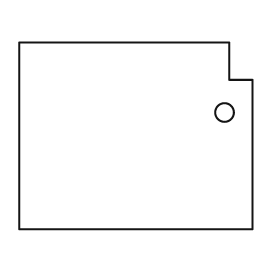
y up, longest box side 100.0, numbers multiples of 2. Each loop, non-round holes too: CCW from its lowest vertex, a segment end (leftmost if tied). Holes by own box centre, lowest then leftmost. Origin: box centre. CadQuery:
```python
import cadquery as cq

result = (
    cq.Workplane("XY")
    .moveTo(-50.0, -40.0)
    .lineTo(50.0, -40.0)
    .lineTo(50.0, 24.0)
    .lineTo(40.0, 24.0)
    .lineTo(40.0, 40.0)
    .lineTo(-50.0, 40.0)
    .close()
    .moveTo(38.0, 10.0)
    .circle(4.0)
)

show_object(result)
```